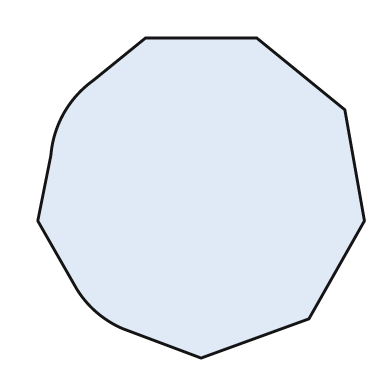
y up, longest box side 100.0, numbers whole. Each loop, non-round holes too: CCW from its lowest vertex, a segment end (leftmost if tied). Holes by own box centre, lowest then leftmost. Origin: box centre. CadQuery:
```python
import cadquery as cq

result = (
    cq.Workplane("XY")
    .moveTo(0.0, -49.0)
    .lineTo(33.0, -37.0)
    .lineTo(50.0, -7.0)
    .lineTo(44.0, 27.0)
    .lineTo(17.0, 49.0)
    .lineTo(-17.0, 49.0)
    .lineTo(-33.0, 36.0)
    .threePointArc((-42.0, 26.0), (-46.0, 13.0))
    .lineTo(-50.0, -7.0)
    .lineTo(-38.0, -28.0)
    .threePointArc((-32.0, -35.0), (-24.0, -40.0))
    .close()
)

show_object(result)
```